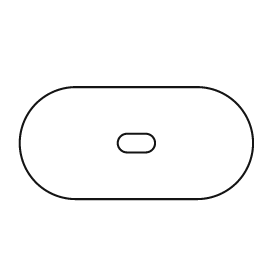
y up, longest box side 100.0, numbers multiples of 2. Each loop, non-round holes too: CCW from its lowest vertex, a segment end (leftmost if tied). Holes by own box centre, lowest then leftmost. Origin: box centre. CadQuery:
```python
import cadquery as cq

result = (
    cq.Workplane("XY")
    .moveTo(-26.0, -24.0)
    .lineTo(26.0, -24.0)
    .threePointArc((50.0, 0.0), (26.0, 24.0))
    .lineTo(-26.0, 24.0)
    .threePointArc((-50.0, 0.0), (-26.0, -24.0))
    .close()
    .moveTo(-4.0, -4.0)
    .lineTo(4.0, -4.0)
    .threePointArc((8.0, 0.0), (4.0, 4.0))
    .lineTo(-4.0, 4.0)
    .threePointArc((-8.0, 0.0), (-4.0, -4.0))
    .close()
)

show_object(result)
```